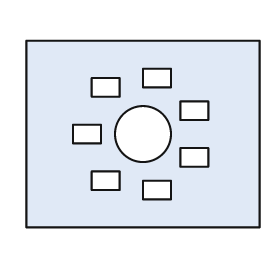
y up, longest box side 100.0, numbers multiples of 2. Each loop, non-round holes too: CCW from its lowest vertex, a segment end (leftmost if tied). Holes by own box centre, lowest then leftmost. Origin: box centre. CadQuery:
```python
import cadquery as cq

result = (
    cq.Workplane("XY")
    .moveTo(-50.0, -40.0)
    .lineTo(50.0, -40.0)
    .lineTo(50.0, 40.0)
    .lineTo(-50.0, 40.0)
    .close()
    .moveTo(0.0, -28.0)
    .lineTo(12.0, -28.0)
    .lineTo(12.0, -20.0)
    .lineTo(0.0, -20.0)
    .close()
    .moveTo(-22.0, -24.0)
    .lineTo(-10.0, -24.0)
    .lineTo(-10.0, -16.0)
    .lineTo(-22.0, -16.0)
    .close()
    .moveTo(16.0, -14.0)
    .lineTo(28.0, -14.0)
    .lineTo(28.0, -6.0)
    .lineTo(16.0, -6.0)
    .close()
    .moveTo(-30.0, -4.0)
    .lineTo(-18.0, -4.0)
    .lineTo(-18.0, 4.0)
    .lineTo(-30.0, 4.0)
    .close()
    .moveTo(0.0, 0.0)
    .circle(12.0)
    .moveTo(16.0, 6.0)
    .lineTo(28.0, 6.0)
    .lineTo(28.0, 14.0)
    .lineTo(16.0, 14.0)
    .close()
    .moveTo(-22.0, 16.0)
    .lineTo(-10.0, 16.0)
    .lineTo(-10.0, 24.0)
    .lineTo(-22.0, 24.0)
    .close()
    .moveTo(0.0, 20.0)
    .lineTo(12.0, 20.0)
    .lineTo(12.0, 28.0)
    .lineTo(0.0, 28.0)
    .close()
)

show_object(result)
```